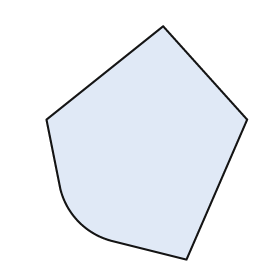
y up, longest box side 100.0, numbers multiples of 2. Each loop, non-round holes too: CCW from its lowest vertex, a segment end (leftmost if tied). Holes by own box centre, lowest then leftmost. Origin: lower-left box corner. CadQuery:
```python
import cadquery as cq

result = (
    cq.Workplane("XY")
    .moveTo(60.0, 0.0)
    .lineTo(86.0, 60.0)
    .lineTo(50.0, 100.0)
    .lineTo(0.0, 60.0)
    .lineTo(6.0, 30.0)
    .threePointArc((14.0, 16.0), (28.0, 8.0))
    .close()
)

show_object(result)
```